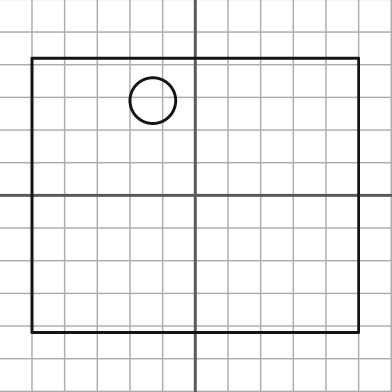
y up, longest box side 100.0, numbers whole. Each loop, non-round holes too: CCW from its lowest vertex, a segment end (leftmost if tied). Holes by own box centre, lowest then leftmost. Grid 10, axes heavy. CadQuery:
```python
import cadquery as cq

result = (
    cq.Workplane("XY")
    .moveTo(-50.0, -42.0)
    .lineTo(50.0, -42.0)
    .lineTo(50.0, 42.0)
    .lineTo(-50.0, 42.0)
    .close()
    .moveTo(-13.0, 29.0)
    .circle(7.0)
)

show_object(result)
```